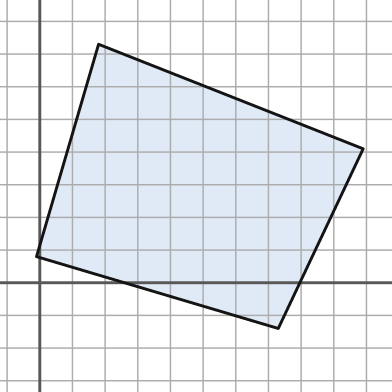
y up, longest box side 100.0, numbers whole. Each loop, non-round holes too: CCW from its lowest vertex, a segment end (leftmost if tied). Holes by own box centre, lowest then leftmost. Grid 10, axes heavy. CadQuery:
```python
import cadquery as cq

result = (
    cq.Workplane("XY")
    .moveTo(73.0, -14.0)
    .lineTo(99.0, 41.0)
    .lineTo(18.0, 73.0)
    .lineTo(-1.0, 8.0)
    .close()
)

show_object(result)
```